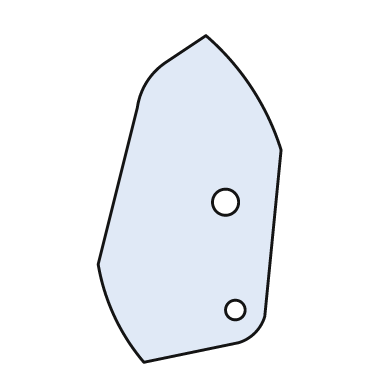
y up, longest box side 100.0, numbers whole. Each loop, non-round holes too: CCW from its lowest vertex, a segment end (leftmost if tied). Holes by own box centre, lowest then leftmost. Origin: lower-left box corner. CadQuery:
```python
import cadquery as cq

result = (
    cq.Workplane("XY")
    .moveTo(14.0, 0.0)
    .lineTo(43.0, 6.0)
    .threePointArc((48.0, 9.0), (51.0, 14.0))
    .lineTo(56.0, 65.0)
    .threePointArc((47.0, 84.0), (33.0, 100.0))
    .lineTo(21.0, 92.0)
    .threePointArc((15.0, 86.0), (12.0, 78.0))
    .lineTo(0.0, 30.0)
    .threePointArc((5.0, 14.0), (14.0, 0.0))
    .close()
    .moveTo(42.0, 16.0)
    .circle(3.0)
    .moveTo(39.0, 49.0)
    .circle(4.0)
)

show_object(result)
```